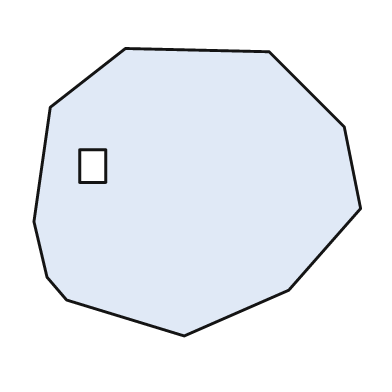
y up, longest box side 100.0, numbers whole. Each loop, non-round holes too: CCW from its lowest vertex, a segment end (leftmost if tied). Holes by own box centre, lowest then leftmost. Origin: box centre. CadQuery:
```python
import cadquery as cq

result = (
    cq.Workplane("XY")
    .moveTo(-4.0, -44.0)
    .lineTo(28.0, -30.0)
    .lineTo(50.0, -5.0)
    .lineTo(45.0, 20.0)
    .lineTo(22.0, 43.0)
    .lineTo(-22.0, 44.0)
    .lineTo(-45.0, 26.0)
    .lineTo(-50.0, -9.0)
    .lineTo(-46.0, -26.0)
    .lineTo(-40.0, -33.0)
    .close()
    .moveTo(-36.0, 3.0)
    .lineTo(-28.0, 3.0)
    .lineTo(-28.0, 13.0)
    .lineTo(-36.0, 13.0)
    .close()
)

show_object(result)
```